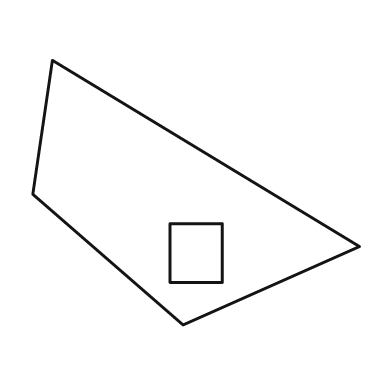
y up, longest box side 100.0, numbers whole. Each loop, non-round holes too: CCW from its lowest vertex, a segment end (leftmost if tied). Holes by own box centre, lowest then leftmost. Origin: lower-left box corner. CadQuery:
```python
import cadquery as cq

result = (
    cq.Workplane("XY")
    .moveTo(46.0, 0.0)
    .lineTo(100.0, 24.0)
    .lineTo(6.0, 81.0)
    .lineTo(0.0, 40.0)
    .close()
    .moveTo(42.0, 13.0)
    .lineTo(58.0, 13.0)
    .lineTo(58.0, 31.0)
    .lineTo(42.0, 31.0)
    .close()
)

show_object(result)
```